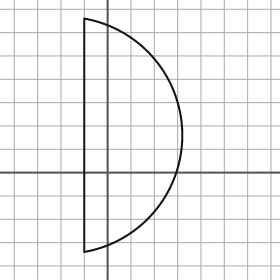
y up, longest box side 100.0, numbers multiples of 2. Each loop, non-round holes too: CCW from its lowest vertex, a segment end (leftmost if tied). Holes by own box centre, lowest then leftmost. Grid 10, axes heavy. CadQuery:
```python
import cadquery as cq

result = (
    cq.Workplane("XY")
    .moveTo(-10.0, -34.0)
    .threePointArc((32.0, 16.0), (-10.0, 66.0))
    .close()
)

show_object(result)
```